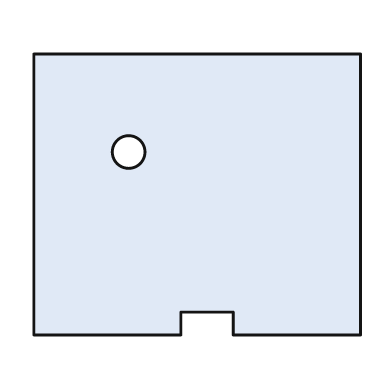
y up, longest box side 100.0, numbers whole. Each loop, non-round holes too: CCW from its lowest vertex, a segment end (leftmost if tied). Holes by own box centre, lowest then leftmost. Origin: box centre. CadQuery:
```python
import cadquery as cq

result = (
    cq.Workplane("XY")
    .moveTo(-50.0, -43.0)
    .lineTo(-5.0, -43.0)
    .lineTo(-5.0, -36.0)
    .lineTo(11.0, -36.0)
    .lineTo(11.0, -43.0)
    .lineTo(50.0, -43.0)
    .lineTo(50.0, 43.0)
    .lineTo(-50.0, 43.0)
    .close()
    .moveTo(-21.0, 13.0)
    .circle(5.0)
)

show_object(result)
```